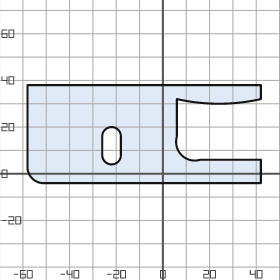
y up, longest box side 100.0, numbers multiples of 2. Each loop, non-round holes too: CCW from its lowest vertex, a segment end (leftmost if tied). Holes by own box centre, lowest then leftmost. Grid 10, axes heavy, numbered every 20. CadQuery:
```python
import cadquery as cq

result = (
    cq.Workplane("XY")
    .moveTo(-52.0, -4.0)
    .lineTo(42.0, -4.0)
    .lineTo(42.0, 6.0)
    .lineTo(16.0, 6.0)
    .threePointArc((8.0, 8.0), (6.0, 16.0))
    .lineTo(6.0, 32.0)
    .threePointArc((24.0, 30.0), (42.0, 32.0))
    .lineTo(42.0, 38.0)
    .lineTo(-58.0, 38.0)
    .lineTo(-58.0, 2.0)
    .threePointArc((-56.0, -2.0), (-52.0, -4.0))
    .close()
    .moveTo(-26.0, 8.0)
    .threePointArc((-22.0, 4.0), (-18.0, 8.0))
    .lineTo(-18.0, 16.0)
    .threePointArc((-22.0, 20.0), (-26.0, 16.0))
    .close()
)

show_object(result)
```